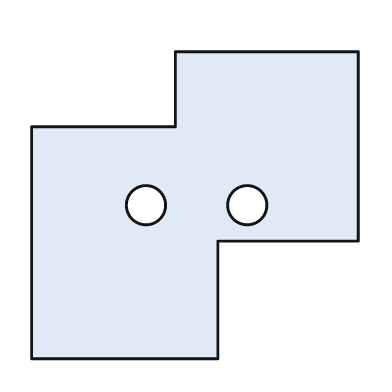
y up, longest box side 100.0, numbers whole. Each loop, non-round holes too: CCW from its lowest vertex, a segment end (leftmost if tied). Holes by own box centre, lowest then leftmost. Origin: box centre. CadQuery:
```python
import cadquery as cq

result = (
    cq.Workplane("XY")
    .moveTo(-50.0, -47.0)
    .lineTo(7.0, -47.0)
    .lineTo(7.0, -11.0)
    .lineTo(50.0, -11.0)
    .lineTo(50.0, 47.0)
    .lineTo(-6.0, 47.0)
    .lineTo(-6.0, 24.0)
    .lineTo(-50.0, 24.0)
    .close()
    .moveTo(-15.0, 0.0)
    .circle(6.0)
    .moveTo(16.0, 0.0)
    .circle(6.0)
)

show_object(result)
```